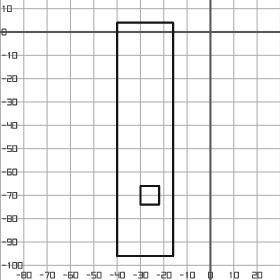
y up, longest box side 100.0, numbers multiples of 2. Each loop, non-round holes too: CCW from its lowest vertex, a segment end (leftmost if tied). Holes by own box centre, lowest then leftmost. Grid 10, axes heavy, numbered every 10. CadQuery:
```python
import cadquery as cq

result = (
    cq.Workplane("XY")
    .moveTo(-40.0, -96.0)
    .lineTo(-16.0, -96.0)
    .lineTo(-16.0, 4.0)
    .lineTo(-40.0, 4.0)
    .close()
    .moveTo(-30.0, -74.0)
    .lineTo(-22.0, -74.0)
    .lineTo(-22.0, -66.0)
    .lineTo(-30.0, -66.0)
    .close()
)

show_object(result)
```